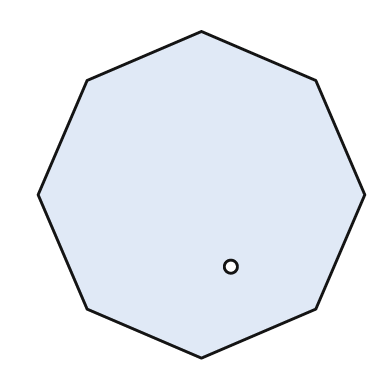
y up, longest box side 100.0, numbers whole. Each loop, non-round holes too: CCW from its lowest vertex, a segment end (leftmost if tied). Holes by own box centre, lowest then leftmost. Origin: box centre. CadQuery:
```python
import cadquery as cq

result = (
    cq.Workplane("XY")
    .moveTo(0.0, -50.0)
    .lineTo(35.0, -35.0)
    .lineTo(50.0, 0.0)
    .lineTo(35.0, 35.0)
    .lineTo(0.0, 50.0)
    .lineTo(-35.0, 35.0)
    .lineTo(-50.0, 0.0)
    .lineTo(-35.0, -35.0)
    .close()
    .moveTo(9.0, -22.0)
    .circle(2.0)
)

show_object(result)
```